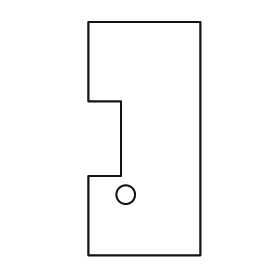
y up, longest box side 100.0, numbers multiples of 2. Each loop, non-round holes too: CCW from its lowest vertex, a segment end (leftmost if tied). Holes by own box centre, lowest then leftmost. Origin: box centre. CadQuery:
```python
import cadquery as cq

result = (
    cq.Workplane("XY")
    .moveTo(-24.0, -50.0)
    .lineTo(24.0, -50.0)
    .lineTo(24.0, 50.0)
    .lineTo(-24.0, 50.0)
    .lineTo(-24.0, 16.0)
    .lineTo(-10.0, 16.0)
    .lineTo(-10.0, -16.0)
    .lineTo(-24.0, -16.0)
    .close()
    .moveTo(-8.0, -24.0)
    .circle(4.0)
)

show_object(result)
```